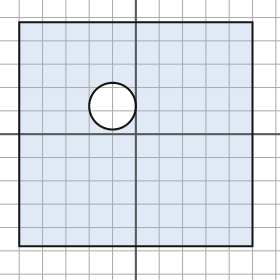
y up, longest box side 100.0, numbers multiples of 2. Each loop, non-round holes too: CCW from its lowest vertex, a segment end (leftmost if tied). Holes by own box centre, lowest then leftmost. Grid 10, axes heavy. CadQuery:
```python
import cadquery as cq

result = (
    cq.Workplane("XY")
    .moveTo(-50.0, -48.0)
    .lineTo(50.0, -48.0)
    .lineTo(50.0, 48.0)
    .lineTo(-50.0, 48.0)
    .close()
    .moveTo(-10.0, 12.0)
    .circle(10.0)
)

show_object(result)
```